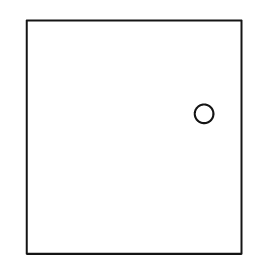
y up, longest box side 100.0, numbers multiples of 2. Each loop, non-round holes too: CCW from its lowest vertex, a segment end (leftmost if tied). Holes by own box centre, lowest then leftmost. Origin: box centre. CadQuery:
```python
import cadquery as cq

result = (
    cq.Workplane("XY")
    .moveTo(-46.0, -50.0)
    .lineTo(46.0, -50.0)
    .lineTo(46.0, 50.0)
    .lineTo(-46.0, 50.0)
    .close()
    .moveTo(30.0, 10.0)
    .circle(4.0)
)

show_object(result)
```